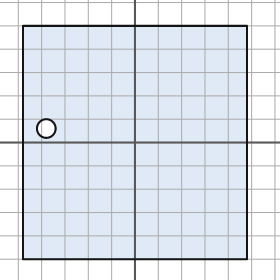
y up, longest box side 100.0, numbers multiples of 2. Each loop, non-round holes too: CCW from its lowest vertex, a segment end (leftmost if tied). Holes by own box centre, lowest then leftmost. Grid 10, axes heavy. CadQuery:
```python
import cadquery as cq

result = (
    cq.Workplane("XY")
    .moveTo(-48.0, -50.0)
    .lineTo(48.0, -50.0)
    .lineTo(48.0, 50.0)
    .lineTo(-48.0, 50.0)
    .close()
    .moveTo(-38.0, 6.0)
    .circle(4.0)
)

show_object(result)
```